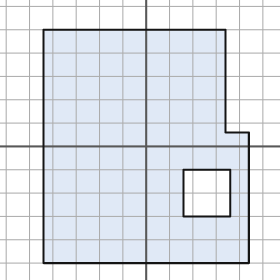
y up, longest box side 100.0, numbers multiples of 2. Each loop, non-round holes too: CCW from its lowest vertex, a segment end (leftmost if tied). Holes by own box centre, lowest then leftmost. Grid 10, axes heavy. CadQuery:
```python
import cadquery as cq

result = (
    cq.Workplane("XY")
    .moveTo(-44.0, -50.0)
    .lineTo(44.0, -50.0)
    .lineTo(44.0, 6.0)
    .lineTo(34.0, 6.0)
    .lineTo(34.0, 50.0)
    .lineTo(-44.0, 50.0)
    .close()
    .moveTo(16.0, -30.0)
    .lineTo(36.0, -30.0)
    .lineTo(36.0, -10.0)
    .lineTo(16.0, -10.0)
    .close()
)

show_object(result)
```